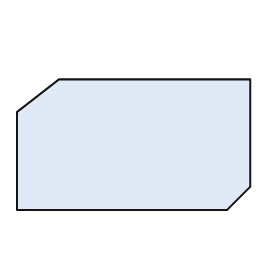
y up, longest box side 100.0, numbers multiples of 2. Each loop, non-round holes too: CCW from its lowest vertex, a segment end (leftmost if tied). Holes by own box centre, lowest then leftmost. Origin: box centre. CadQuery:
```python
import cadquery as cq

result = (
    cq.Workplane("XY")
    .moveTo(-50.0, -28.0)
    .lineTo(40.0, -28.0)
    .lineTo(50.0, -18.0)
    .lineTo(50.0, 28.0)
    .lineTo(-32.0, 28.0)
    .lineTo(-50.0, 14.0)
    .close()
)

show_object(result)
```